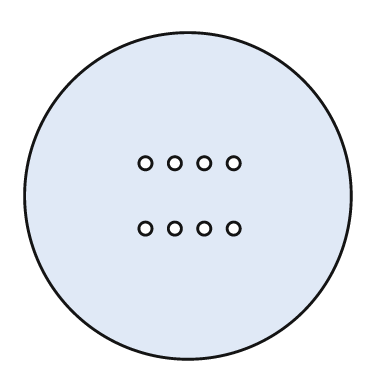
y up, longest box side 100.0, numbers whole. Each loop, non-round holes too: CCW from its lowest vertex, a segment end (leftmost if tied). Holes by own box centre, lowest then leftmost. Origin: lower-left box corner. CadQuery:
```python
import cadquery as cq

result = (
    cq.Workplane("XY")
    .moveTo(50.0, 50.0)
    .circle(50.0)
    .moveTo(37.0, 40.0)
    .circle(2.0)
    .moveTo(46.0, 40.0)
    .circle(2.0)
    .moveTo(55.0, 40.0)
    .circle(2.0)
    .moveTo(64.0, 40.0)
    .circle(2.0)
    .moveTo(37.0, 60.0)
    .circle(2.0)
    .moveTo(46.0, 60.0)
    .circle(2.0)
    .moveTo(55.0, 60.0)
    .circle(2.0)
    .moveTo(64.0, 60.0)
    .circle(2.0)
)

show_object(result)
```